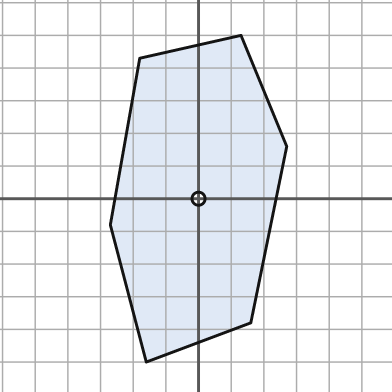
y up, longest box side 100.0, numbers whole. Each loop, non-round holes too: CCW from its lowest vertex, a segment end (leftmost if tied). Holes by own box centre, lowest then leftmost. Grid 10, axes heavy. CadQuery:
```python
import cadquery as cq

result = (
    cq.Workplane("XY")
    .moveTo(-16.0, -50.0)
    .lineTo(16.0, -38.0)
    .lineTo(27.0, 16.0)
    .lineTo(13.0, 50.0)
    .lineTo(-18.0, 43.0)
    .lineTo(-27.0, -8.0)
    .close()
    .moveTo(0.0, 0.0)
    .circle(2.0)
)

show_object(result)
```